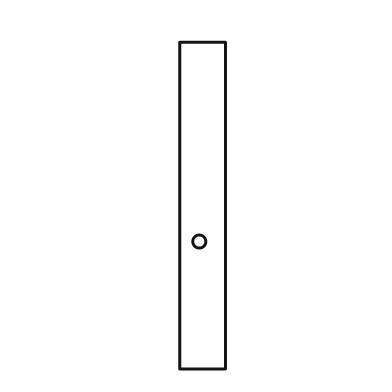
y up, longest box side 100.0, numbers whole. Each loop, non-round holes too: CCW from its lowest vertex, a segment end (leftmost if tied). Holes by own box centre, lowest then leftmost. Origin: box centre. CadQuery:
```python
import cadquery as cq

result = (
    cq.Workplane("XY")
    .moveTo(-7.0, -50.0)
    .lineTo(7.0, -50.0)
    .lineTo(7.0, 50.0)
    .lineTo(-7.0, 50.0)
    .close()
    .moveTo(-1.0, -11.0)
    .circle(2.0)
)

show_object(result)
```